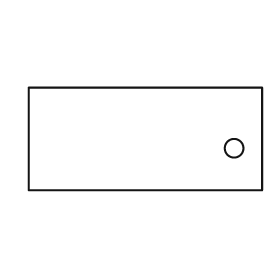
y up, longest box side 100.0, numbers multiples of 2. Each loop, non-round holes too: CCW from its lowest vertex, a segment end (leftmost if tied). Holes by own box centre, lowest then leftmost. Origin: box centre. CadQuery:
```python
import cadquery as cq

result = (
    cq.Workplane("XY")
    .moveTo(-50.0, -22.0)
    .lineTo(50.0, -22.0)
    .lineTo(50.0, 22.0)
    .lineTo(-50.0, 22.0)
    .close()
    .moveTo(38.0, -4.0)
    .circle(4.0)
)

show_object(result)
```